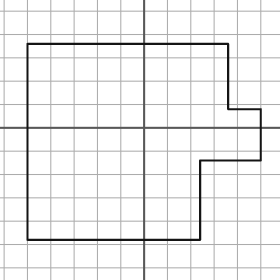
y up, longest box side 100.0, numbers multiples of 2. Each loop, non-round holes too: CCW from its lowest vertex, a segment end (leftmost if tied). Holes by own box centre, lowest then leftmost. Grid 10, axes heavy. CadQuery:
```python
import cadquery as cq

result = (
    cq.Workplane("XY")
    .moveTo(-50.0, -48.0)
    .lineTo(24.0, -48.0)
    .lineTo(24.0, -14.0)
    .lineTo(50.0, -14.0)
    .lineTo(50.0, 8.0)
    .lineTo(36.0, 8.0)
    .lineTo(36.0, 36.0)
    .lineTo(-50.0, 36.0)
    .close()
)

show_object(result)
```